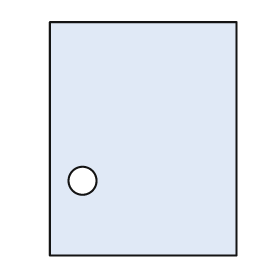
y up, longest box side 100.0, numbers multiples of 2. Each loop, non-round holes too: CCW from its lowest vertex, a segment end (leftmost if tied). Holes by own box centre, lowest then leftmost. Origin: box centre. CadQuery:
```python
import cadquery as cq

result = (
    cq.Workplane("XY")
    .moveTo(-40.0, -50.0)
    .lineTo(40.0, -50.0)
    .lineTo(40.0, 50.0)
    .lineTo(-40.0, 50.0)
    .close()
    .moveTo(-26.0, -18.0)
    .circle(6.0)
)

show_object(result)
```